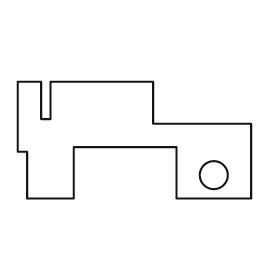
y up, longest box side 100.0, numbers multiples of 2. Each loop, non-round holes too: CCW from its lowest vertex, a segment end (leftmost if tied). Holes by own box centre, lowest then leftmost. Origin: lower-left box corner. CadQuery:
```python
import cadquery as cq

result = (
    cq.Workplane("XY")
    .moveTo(4.0, 0.0)
    .lineTo(24.0, 0.0)
    .lineTo(24.0, 22.0)
    .lineTo(68.0, 22.0)
    .lineTo(68.0, 0.0)
    .lineTo(100.0, 0.0)
    .lineTo(100.0, 32.0)
    .lineTo(58.0, 32.0)
    .lineTo(58.0, 50.0)
    .lineTo(14.0, 50.0)
    .lineTo(14.0, 34.0)
    .lineTo(10.0, 34.0)
    .lineTo(10.0, 50.0)
    .lineTo(0.0, 50.0)
    .lineTo(0.0, 20.0)
    .lineTo(4.0, 20.0)
    .close()
    .moveTo(84.0, 10.0)
    .circle(6.0)
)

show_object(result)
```